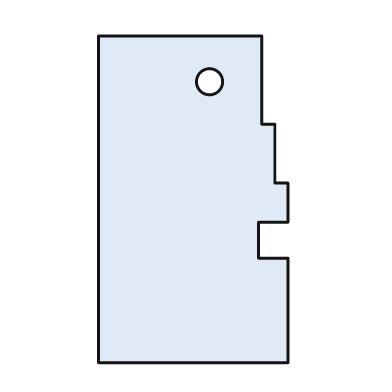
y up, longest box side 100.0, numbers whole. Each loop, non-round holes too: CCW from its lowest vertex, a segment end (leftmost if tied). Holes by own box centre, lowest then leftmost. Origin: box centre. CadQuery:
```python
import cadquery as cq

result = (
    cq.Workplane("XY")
    .moveTo(-29.0, -50.0)
    .lineTo(29.0, -50.0)
    .lineTo(29.0, -18.0)
    .lineTo(20.0, -18.0)
    .lineTo(20.0, -7.0)
    .lineTo(29.0, -7.0)
    .lineTo(29.0, 5.0)
    .lineTo(25.0, 5.0)
    .lineTo(25.0, 23.0)
    .lineTo(21.0, 23.0)
    .lineTo(21.0, 50.0)
    .lineTo(-29.0, 50.0)
    .close()
    .moveTo(5.0, 36.0)
    .circle(4.0)
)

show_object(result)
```